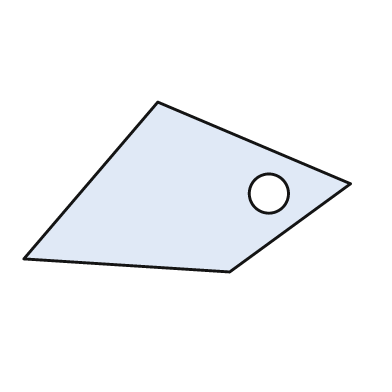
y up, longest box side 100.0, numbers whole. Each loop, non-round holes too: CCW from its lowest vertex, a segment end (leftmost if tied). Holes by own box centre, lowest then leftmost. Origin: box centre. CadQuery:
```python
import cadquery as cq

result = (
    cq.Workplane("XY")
    .moveTo(13.0, -26.0)
    .lineTo(50.0, 1.0)
    .lineTo(-9.0, 26.0)
    .lineTo(-50.0, -22.0)
    .close()
    .moveTo(25.0, -2.0)
    .circle(6.0)
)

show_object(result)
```